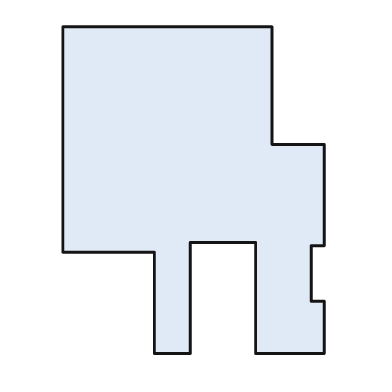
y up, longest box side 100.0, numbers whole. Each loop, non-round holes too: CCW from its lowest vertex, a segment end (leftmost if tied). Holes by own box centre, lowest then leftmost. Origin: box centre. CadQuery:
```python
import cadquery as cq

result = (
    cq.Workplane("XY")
    .moveTo(-12.0, -50.0)
    .lineTo(-1.0, -50.0)
    .lineTo(-1.0, -16.0)
    .lineTo(19.0, -16.0)
    .lineTo(19.0, -50.0)
    .lineTo(40.0, -50.0)
    .lineTo(40.0, -34.0)
    .lineTo(36.0, -34.0)
    .lineTo(36.0, -17.0)
    .lineTo(40.0, -17.0)
    .lineTo(40.0, 14.0)
    .lineTo(24.0, 14.0)
    .lineTo(24.0, 50.0)
    .lineTo(-40.0, 50.0)
    .lineTo(-40.0, -19.0)
    .lineTo(-12.0, -19.0)
    .close()
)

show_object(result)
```